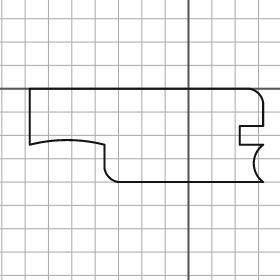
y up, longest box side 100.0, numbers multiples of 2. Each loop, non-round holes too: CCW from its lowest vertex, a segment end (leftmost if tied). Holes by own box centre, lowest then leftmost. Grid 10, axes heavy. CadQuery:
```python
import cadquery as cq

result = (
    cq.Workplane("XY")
    .moveTo(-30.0, -40.0)
    .lineTo(32.0, -40.0)
    .threePointArc((28.0, -32.0), (32.0, -24.0))
    .lineTo(22.0, -24.0)
    .lineTo(22.0, -16.0)
    .lineTo(32.0, -16.0)
    .lineTo(32.0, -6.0)
    .threePointArc((30.0, -2.0), (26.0, 0.0))
    .lineTo(-68.0, 0.0)
    .lineTo(-68.0, -24.0)
    .threePointArc((-52.0, -22.0), (-36.0, -24.0))
    .lineTo(-36.0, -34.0)
    .threePointArc((-34.0, -38.0), (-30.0, -40.0))
    .close()
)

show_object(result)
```